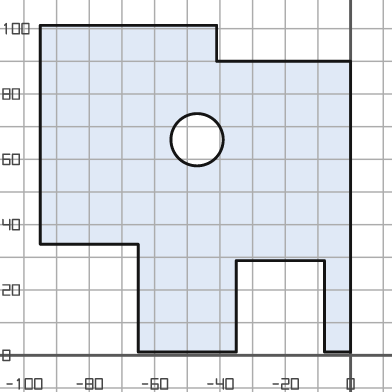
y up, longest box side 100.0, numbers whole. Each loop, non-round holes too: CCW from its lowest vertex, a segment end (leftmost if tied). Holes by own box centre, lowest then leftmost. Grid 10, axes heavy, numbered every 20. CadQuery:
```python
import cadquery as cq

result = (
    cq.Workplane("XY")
    .moveTo(-65.0, 1.0)
    .lineTo(-35.0, 1.0)
    .lineTo(-35.0, 29.0)
    .lineTo(-8.0, 29.0)
    .lineTo(-8.0, 1.0)
    .lineTo(0.0, 1.0)
    .lineTo(0.0, 90.0)
    .lineTo(-41.0, 90.0)
    .lineTo(-41.0, 101.0)
    .lineTo(-95.0, 101.0)
    .lineTo(-95.0, 34.0)
    .lineTo(-65.0, 34.0)
    .close()
    .moveTo(-47.0, 66.0)
    .circle(8.0)
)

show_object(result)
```